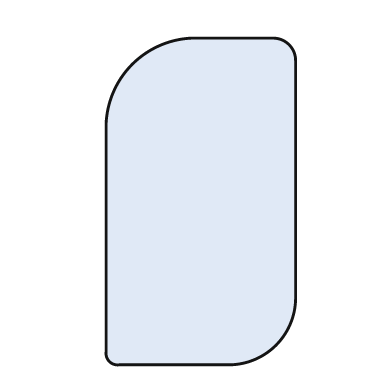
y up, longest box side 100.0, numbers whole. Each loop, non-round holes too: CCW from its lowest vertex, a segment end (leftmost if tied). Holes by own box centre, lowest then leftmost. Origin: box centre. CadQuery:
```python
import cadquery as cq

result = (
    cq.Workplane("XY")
    .moveTo(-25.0, -50.0)
    .lineTo(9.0, -50.0)
    .threePointArc((23.0, -44.0), (29.0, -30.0))
    .lineTo(29.0, 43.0)
    .threePointArc((27.0, 48.0), (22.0, 50.0))
    .lineTo(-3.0, 50.0)
    .threePointArc((-21.0, 42.0), (-29.0, 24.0))
    .lineTo(-29.0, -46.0)
    .threePointArc((-28.0, -49.0), (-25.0, -50.0))
    .close()
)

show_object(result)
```